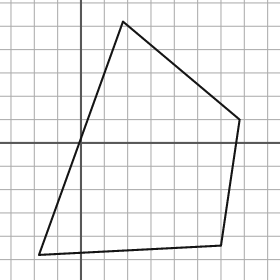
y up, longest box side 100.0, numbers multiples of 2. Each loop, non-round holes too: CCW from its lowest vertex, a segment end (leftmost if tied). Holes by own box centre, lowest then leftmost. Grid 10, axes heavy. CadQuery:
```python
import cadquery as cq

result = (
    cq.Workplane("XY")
    .moveTo(-18.0, -48.0)
    .lineTo(60.0, -44.0)
    .lineTo(68.0, 10.0)
    .lineTo(18.0, 52.0)
    .close()
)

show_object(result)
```